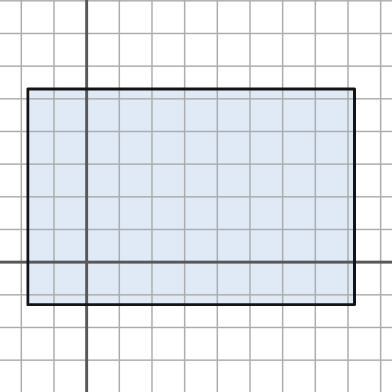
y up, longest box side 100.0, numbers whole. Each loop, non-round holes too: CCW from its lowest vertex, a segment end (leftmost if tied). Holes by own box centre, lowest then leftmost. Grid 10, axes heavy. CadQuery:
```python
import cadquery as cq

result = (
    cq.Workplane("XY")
    .moveTo(-18.0, -13.0)
    .lineTo(82.0, -13.0)
    .lineTo(82.0, 53.0)
    .lineTo(-18.0, 53.0)
    .close()
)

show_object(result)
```